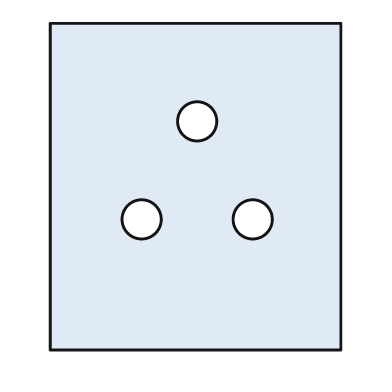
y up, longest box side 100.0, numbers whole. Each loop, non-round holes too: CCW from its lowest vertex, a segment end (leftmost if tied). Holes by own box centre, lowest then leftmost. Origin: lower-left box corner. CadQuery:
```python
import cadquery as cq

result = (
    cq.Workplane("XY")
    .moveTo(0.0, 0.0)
    .lineTo(89.0, 0.0)
    .lineTo(89.0, 100.0)
    .lineTo(0.0, 100.0)
    .close()
    .moveTo(28.0, 40.0)
    .circle(6.0)
    .moveTo(62.0, 40.0)
    .circle(6.0)
    .moveTo(45.0, 70.0)
    .circle(6.0)
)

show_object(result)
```